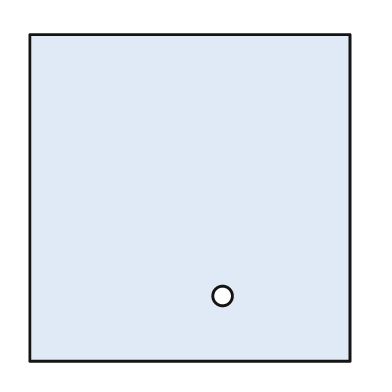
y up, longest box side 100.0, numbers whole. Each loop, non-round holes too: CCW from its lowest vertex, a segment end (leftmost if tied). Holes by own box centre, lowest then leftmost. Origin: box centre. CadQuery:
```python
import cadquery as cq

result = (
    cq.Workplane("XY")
    .moveTo(-49.0, -50.0)
    .lineTo(49.0, -50.0)
    .lineTo(49.0, 50.0)
    .lineTo(-49.0, 50.0)
    .close()
    .moveTo(10.0, -30.0)
    .circle(3.0)
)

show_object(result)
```